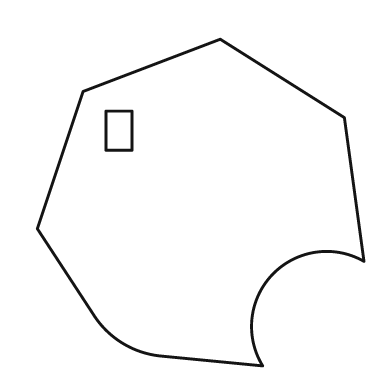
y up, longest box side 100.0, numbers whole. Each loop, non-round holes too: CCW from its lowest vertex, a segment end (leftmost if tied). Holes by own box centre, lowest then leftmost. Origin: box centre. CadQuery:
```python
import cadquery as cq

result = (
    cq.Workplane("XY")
    .moveTo(19.0, -50.0)
    .threePointArc((22.0, -22.0), (50.0, -18.0))
    .lineTo(44.0, 26.0)
    .lineTo(6.0, 50.0)
    .lineTo(-36.0, 34.0)
    .lineTo(-50.0, -8.0)
    .lineTo(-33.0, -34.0)
    .threePointArc((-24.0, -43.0), (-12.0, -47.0))
    .close()
    .moveTo(-29.0, 16.0)
    .lineTo(-21.0, 16.0)
    .lineTo(-21.0, 28.0)
    .lineTo(-29.0, 28.0)
    .close()
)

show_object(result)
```